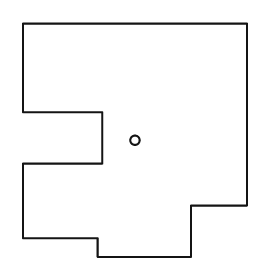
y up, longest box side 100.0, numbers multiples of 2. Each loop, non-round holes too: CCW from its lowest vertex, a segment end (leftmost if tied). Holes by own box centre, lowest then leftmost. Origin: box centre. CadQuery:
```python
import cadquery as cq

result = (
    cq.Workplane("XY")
    .moveTo(-16.0, -50.0)
    .lineTo(24.0, -50.0)
    .lineTo(24.0, -28.0)
    .lineTo(48.0, -28.0)
    .lineTo(48.0, 50.0)
    .lineTo(-48.0, 50.0)
    .lineTo(-48.0, 12.0)
    .lineTo(-14.0, 12.0)
    .lineTo(-14.0, -10.0)
    .lineTo(-48.0, -10.0)
    .lineTo(-48.0, -42.0)
    .lineTo(-16.0, -42.0)
    .close()
    .moveTo(0.0, 0.0)
    .circle(2.0)
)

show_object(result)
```